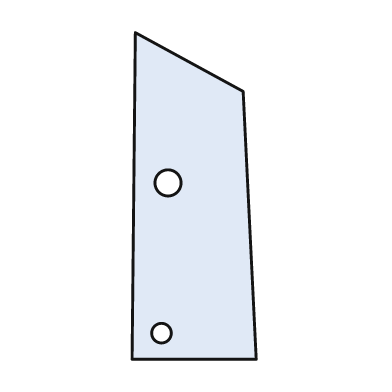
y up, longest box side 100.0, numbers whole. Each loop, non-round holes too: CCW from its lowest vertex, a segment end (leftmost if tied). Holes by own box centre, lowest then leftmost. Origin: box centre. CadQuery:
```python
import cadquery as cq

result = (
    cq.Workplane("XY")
    .moveTo(-19.0, -50.0)
    .lineTo(19.0, -50.0)
    .lineTo(15.0, 32.0)
    .lineTo(-18.0, 50.0)
    .close()
    .moveTo(-10.0, -42.0)
    .circle(3.0)
    .moveTo(-8.0, 4.0)
    .circle(4.0)
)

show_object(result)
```